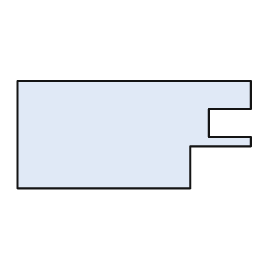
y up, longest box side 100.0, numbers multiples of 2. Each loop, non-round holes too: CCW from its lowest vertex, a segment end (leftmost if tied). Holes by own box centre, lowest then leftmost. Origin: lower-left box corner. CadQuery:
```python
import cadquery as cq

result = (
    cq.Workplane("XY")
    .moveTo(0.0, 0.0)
    .lineTo(74.0, 0.0)
    .lineTo(74.0, 18.0)
    .lineTo(100.0, 18.0)
    .lineTo(100.0, 22.0)
    .lineTo(82.0, 22.0)
    .lineTo(82.0, 34.0)
    .lineTo(100.0, 34.0)
    .lineTo(100.0, 46.0)
    .lineTo(0.0, 46.0)
    .close()
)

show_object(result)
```